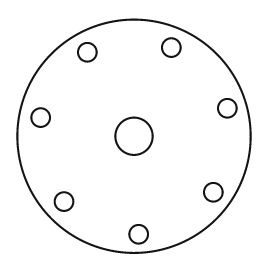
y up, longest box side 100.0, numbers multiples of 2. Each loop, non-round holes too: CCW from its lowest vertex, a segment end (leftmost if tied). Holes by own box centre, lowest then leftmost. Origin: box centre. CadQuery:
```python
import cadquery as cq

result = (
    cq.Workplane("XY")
    .moveTo(0.0, 0.0)
    .circle(50.0)
    .moveTo(2.0, -42.0)
    .circle(4.0)
    .moveTo(-30.0, -28.0)
    .circle(4.0)
    .moveTo(34.0, -24.0)
    .circle(4.0)
    .moveTo(0.0, 0.0)
    .circle(8.0)
    .moveTo(-40.0, 8.0)
    .circle(4.0)
    .moveTo(40.0, 12.0)
    .circle(4.0)
    .moveTo(-20.0, 36.0)
    .circle(4.0)
    .moveTo(16.0, 38.0)
    .circle(4.0)
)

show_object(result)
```